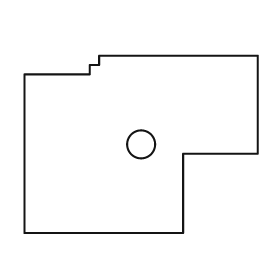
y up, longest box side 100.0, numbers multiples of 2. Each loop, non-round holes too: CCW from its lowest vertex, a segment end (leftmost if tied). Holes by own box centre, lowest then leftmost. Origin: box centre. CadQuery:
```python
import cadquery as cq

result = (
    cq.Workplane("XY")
    .moveTo(-50.0, -38.0)
    .lineTo(18.0, -38.0)
    .lineTo(18.0, -4.0)
    .lineTo(50.0, -4.0)
    .lineTo(50.0, 38.0)
    .lineTo(-18.0, 38.0)
    .lineTo(-18.0, 34.0)
    .lineTo(-22.0, 34.0)
    .lineTo(-22.0, 30.0)
    .lineTo(-50.0, 30.0)
    .close()
    .moveTo(0.0, 0.0)
    .circle(6.0)
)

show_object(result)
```